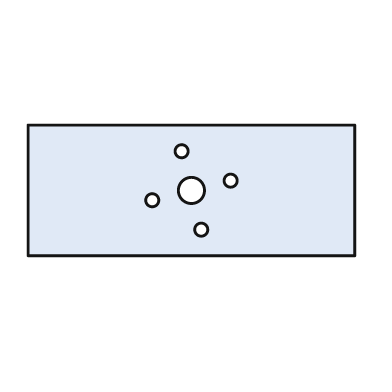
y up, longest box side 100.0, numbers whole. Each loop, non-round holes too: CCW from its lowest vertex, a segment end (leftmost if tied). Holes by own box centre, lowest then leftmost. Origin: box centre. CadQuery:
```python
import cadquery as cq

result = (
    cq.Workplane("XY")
    .moveTo(-50.0, -20.0)
    .lineTo(50.0, -20.0)
    .lineTo(50.0, 20.0)
    .lineTo(-50.0, 20.0)
    .close()
    .moveTo(3.0, -12.0)
    .circle(2.0)
    .moveTo(-12.0, -3.0)
    .circle(2.0)
    .moveTo(0.0, 0.0)
    .circle(4.0)
    .moveTo(12.0, 3.0)
    .circle(2.0)
    .moveTo(-3.0, 12.0)
    .circle(2.0)
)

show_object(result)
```